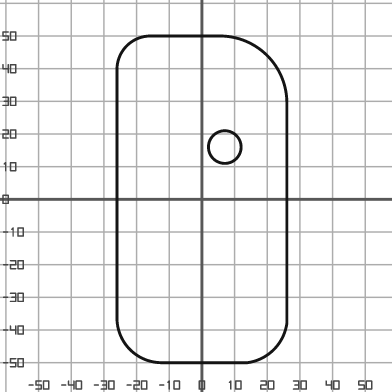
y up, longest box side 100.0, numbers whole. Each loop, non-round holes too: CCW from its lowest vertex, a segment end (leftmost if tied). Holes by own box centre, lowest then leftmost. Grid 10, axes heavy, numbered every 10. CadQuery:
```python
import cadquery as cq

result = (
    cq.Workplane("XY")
    .moveTo(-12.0, -50.0)
    .lineTo(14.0, -50.0)
    .threePointArc((22.0, -46.0), (26.0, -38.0))
    .lineTo(26.0, 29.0)
    .threePointArc((20.0, 44.0), (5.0, 50.0))
    .lineTo(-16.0, 50.0)
    .threePointArc((-23.0, 47.0), (-26.0, 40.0))
    .lineTo(-26.0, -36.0)
    .threePointArc((-22.0, -46.0), (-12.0, -50.0))
    .close()
    .moveTo(7.0, 16.0)
    .circle(5.0)
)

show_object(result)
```